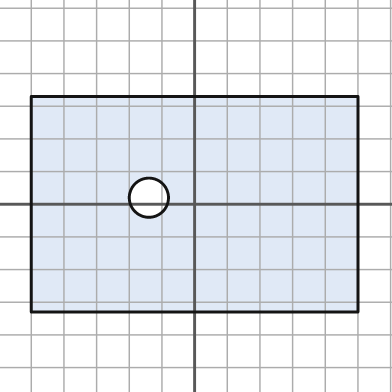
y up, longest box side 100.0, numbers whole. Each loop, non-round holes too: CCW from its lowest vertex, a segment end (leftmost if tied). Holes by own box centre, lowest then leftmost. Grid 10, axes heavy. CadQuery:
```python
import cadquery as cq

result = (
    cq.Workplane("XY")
    .moveTo(-50.0, -33.0)
    .lineTo(50.0, -33.0)
    .lineTo(50.0, 33.0)
    .lineTo(-50.0, 33.0)
    .close()
    .moveTo(-14.0, 2.0)
    .circle(6.0)
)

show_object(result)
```